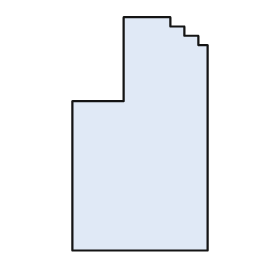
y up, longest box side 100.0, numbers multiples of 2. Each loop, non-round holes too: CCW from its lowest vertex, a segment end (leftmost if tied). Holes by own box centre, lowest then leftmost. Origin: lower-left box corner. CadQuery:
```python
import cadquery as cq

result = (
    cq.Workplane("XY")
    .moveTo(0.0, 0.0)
    .lineTo(58.0, 0.0)
    .lineTo(58.0, 88.0)
    .lineTo(54.0, 88.0)
    .lineTo(54.0, 92.0)
    .lineTo(48.0, 92.0)
    .lineTo(48.0, 96.0)
    .lineTo(42.0, 96.0)
    .lineTo(42.0, 100.0)
    .lineTo(22.0, 100.0)
    .lineTo(22.0, 64.0)
    .lineTo(0.0, 64.0)
    .close()
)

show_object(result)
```